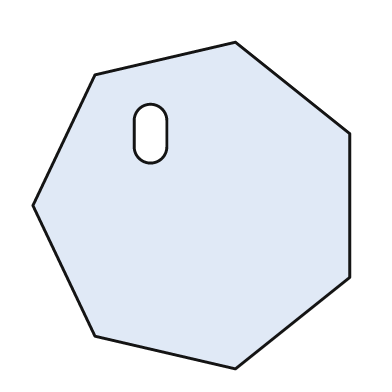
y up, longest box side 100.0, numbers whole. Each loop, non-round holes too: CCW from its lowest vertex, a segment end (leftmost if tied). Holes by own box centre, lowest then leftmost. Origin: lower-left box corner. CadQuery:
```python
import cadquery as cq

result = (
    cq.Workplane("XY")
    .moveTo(62.0, 0.0)
    .lineTo(97.0, 28.0)
    .lineTo(97.0, 72.0)
    .lineTo(62.0, 100.0)
    .lineTo(19.0, 90.0)
    .lineTo(0.0, 50.0)
    .lineTo(19.0, 10.0)
    .close()
    .moveTo(31.0, 68.0)
    .threePointArc((36.0, 63.0), (41.0, 68.0))
    .lineTo(41.0, 76.0)
    .threePointArc((36.0, 81.0), (31.0, 76.0))
    .close()
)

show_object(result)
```